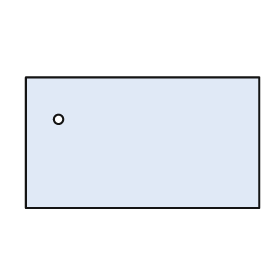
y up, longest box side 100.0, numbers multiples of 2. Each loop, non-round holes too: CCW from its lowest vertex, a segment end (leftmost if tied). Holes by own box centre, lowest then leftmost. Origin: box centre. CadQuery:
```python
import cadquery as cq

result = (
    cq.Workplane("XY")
    .moveTo(-50.0, -28.0)
    .lineTo(50.0, -28.0)
    .lineTo(50.0, 28.0)
    .lineTo(-50.0, 28.0)
    .close()
    .moveTo(-36.0, 10.0)
    .circle(2.0)
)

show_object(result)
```